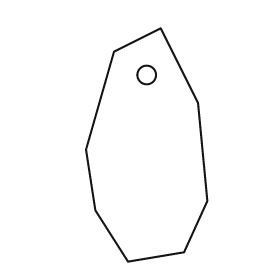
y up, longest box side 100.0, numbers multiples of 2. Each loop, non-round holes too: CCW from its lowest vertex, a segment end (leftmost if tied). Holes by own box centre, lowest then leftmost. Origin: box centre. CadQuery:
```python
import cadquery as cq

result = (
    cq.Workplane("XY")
    .moveTo(-8.0, -50.0)
    .lineTo(16.0, -46.0)
    .lineTo(26.0, -24.0)
    .lineTo(22.0, 18.0)
    .lineTo(6.0, 50.0)
    .lineTo(-14.0, 40.0)
    .lineTo(-26.0, -2.0)
    .lineTo(-22.0, -28.0)
    .close()
    .moveTo(0.0, 30.0)
    .circle(4.0)
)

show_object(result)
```